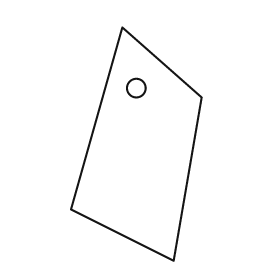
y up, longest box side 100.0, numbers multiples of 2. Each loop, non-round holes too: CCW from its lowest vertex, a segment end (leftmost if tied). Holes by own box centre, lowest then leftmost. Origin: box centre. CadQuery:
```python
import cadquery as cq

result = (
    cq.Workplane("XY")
    .moveTo(16.0, -50.0)
    .lineTo(28.0, 20.0)
    .lineTo(-6.0, 50.0)
    .lineTo(-28.0, -28.0)
    .close()
    .moveTo(0.0, 24.0)
    .circle(4.0)
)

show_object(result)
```